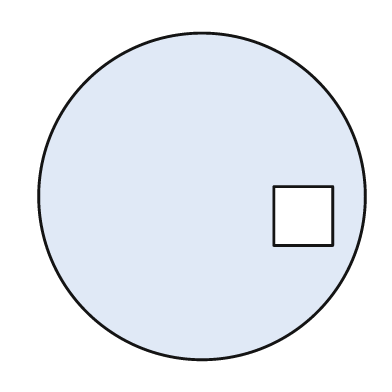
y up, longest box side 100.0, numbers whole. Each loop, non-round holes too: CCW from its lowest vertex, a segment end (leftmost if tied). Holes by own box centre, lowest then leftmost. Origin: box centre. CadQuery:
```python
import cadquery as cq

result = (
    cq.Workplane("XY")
    .moveTo(0.0, 0.0)
    .circle(50.0)
    .moveTo(22.0, -15.0)
    .lineTo(40.0, -15.0)
    .lineTo(40.0, 3.0)
    .lineTo(22.0, 3.0)
    .close()
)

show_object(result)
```